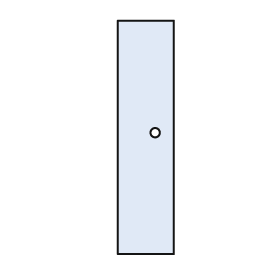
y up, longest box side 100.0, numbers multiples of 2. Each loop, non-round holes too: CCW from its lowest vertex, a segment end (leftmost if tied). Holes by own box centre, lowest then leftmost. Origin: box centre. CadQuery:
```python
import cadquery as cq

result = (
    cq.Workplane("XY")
    .moveTo(-12.0, -50.0)
    .lineTo(12.0, -50.0)
    .lineTo(12.0, 50.0)
    .lineTo(-12.0, 50.0)
    .close()
    .moveTo(4.0, 2.0)
    .circle(2.0)
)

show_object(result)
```